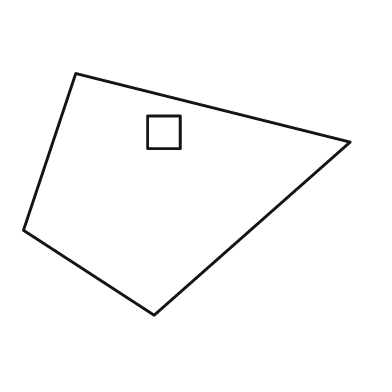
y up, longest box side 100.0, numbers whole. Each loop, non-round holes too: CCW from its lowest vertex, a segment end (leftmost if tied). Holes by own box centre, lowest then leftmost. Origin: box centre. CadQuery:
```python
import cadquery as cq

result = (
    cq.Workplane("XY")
    .moveTo(-10.0, -37.0)
    .lineTo(50.0, 16.0)
    .lineTo(-34.0, 37.0)
    .lineTo(-50.0, -11.0)
    .close()
    .moveTo(-12.0, 14.0)
    .lineTo(-2.0, 14.0)
    .lineTo(-2.0, 24.0)
    .lineTo(-12.0, 24.0)
    .close()
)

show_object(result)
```